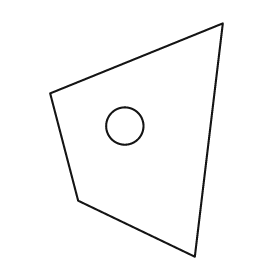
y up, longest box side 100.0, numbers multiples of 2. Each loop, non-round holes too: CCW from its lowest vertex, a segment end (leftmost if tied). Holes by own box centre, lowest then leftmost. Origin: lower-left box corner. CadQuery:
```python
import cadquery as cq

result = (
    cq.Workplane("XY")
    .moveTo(62.0, 0.0)
    .lineTo(74.0, 100.0)
    .lineTo(0.0, 70.0)
    .lineTo(12.0, 24.0)
    .close()
    .moveTo(32.0, 56.0)
    .circle(8.0)
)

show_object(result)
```